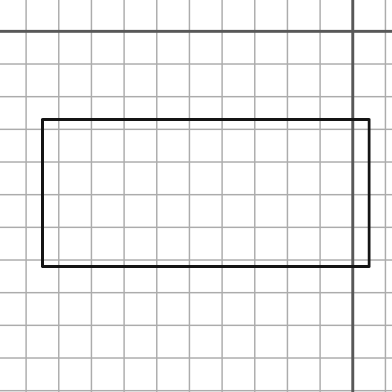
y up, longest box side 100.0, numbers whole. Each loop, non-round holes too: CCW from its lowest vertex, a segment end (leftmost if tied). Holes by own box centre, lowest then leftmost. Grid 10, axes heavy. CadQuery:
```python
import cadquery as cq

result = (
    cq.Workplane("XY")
    .moveTo(-95.0, -72.0)
    .lineTo(5.0, -72.0)
    .lineTo(5.0, -27.0)
    .lineTo(-95.0, -27.0)
    .close()
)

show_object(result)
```